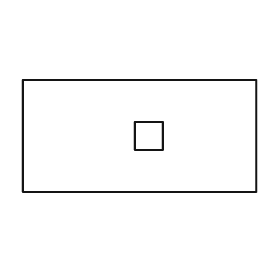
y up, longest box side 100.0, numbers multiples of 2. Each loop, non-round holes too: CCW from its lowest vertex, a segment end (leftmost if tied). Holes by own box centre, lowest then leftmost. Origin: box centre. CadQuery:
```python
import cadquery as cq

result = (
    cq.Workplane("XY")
    .moveTo(-50.0, -24.0)
    .lineTo(50.0, -24.0)
    .lineTo(50.0, 24.0)
    .lineTo(-50.0, 24.0)
    .close()
    .moveTo(-2.0, -6.0)
    .lineTo(10.0, -6.0)
    .lineTo(10.0, 6.0)
    .lineTo(-2.0, 6.0)
    .close()
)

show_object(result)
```